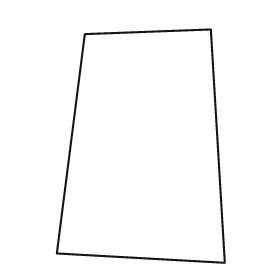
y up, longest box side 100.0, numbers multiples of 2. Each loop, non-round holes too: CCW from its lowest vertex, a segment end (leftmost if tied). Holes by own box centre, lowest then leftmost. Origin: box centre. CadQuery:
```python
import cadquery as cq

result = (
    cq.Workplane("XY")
    .moveTo(36.0, -50.0)
    .lineTo(30.0, 50.0)
    .lineTo(-24.0, 48.0)
    .lineTo(-36.0, -46.0)
    .close()
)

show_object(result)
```